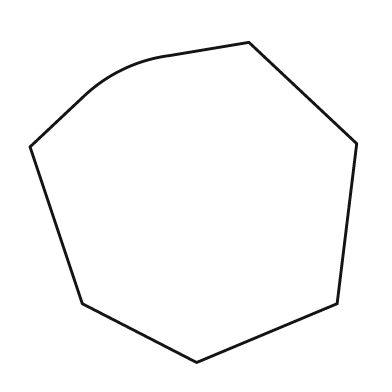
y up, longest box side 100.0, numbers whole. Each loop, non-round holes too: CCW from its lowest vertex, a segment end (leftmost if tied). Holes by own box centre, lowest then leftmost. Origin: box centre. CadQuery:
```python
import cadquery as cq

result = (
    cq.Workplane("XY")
    .moveTo(1.0, -49.0)
    .lineTo(44.0, -31.0)
    .lineTo(50.0, 18.0)
    .lineTo(17.0, 49.0)
    .lineTo(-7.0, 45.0)
    .threePointArc((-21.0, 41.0), (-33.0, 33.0))
    .lineTo(-50.0, 17.0)
    .lineTo(-34.0, -31.0)
    .close()
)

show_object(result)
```